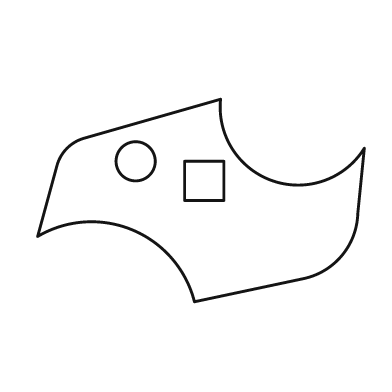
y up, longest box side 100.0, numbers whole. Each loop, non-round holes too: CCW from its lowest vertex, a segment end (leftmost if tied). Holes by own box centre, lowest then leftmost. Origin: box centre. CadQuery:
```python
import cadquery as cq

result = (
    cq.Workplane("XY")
    .moveTo(-2.0, -31.0)
    .lineTo(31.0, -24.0)
    .threePointArc((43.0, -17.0), (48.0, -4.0))
    .lineTo(50.0, 16.0)
    .threePointArc((22.0, 6.0), (6.0, 31.0))
    .lineTo(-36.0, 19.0)
    .threePointArc((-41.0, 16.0), (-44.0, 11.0))
    .lineTo(-50.0, -11.0)
    .threePointArc((-21.0, -9.0), (-2.0, -31.0))
    .close()
    .moveTo(-5.0, 0.0)
    .lineTo(7.0, 0.0)
    .lineTo(7.0, 12.0)
    .lineTo(-5.0, 12.0)
    .close()
    .moveTo(-20.0, 12.0)
    .circle(6.0)
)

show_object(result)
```